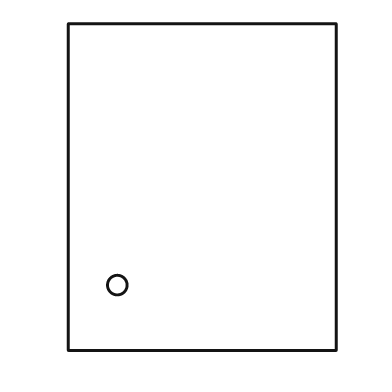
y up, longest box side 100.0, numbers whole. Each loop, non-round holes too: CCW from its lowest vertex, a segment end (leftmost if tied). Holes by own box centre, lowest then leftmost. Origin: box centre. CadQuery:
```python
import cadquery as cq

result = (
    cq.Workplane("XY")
    .moveTo(-41.0, -50.0)
    .lineTo(41.0, -50.0)
    .lineTo(41.0, 50.0)
    .lineTo(-41.0, 50.0)
    .close()
    .moveTo(-26.0, -30.0)
    .circle(3.0)
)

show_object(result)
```